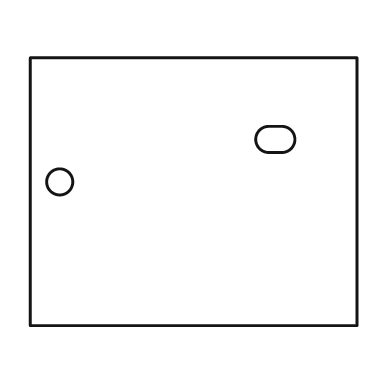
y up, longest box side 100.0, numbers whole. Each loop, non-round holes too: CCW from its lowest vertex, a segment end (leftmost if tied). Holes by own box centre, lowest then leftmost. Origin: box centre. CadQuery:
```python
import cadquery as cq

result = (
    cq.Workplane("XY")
    .moveTo(-50.0, -41.0)
    .lineTo(50.0, -41.0)
    .lineTo(50.0, 41.0)
    .lineTo(-50.0, 41.0)
    .close()
    .moveTo(-41.0, 3.0)
    .circle(4.0)
    .moveTo(23.0, 12.0)
    .lineTo(27.0, 12.0)
    .threePointArc((31.0, 16.0), (27.0, 20.0))
    .lineTo(23.0, 20.0)
    .threePointArc((19.0, 16.0), (23.0, 12.0))
    .close()
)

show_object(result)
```